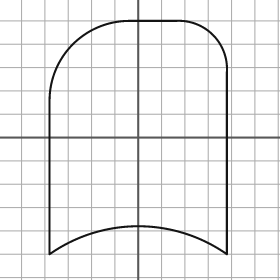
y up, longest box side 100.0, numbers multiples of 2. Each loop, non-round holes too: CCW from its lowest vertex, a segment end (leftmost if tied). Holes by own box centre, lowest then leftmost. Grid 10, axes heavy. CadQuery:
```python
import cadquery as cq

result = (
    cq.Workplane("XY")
    .moveTo(-38.0, -50.0)
    .threePointArc((0.0, -38.0), (38.0, -50.0))
    .lineTo(38.0, 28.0)
    .threePointArc((32.0, 44.0), (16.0, 50.0))
    .lineTo(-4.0, 50.0)
    .threePointArc((-28.0, 40.0), (-38.0, 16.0))
    .close()
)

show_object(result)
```